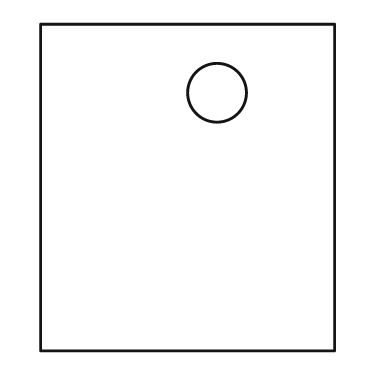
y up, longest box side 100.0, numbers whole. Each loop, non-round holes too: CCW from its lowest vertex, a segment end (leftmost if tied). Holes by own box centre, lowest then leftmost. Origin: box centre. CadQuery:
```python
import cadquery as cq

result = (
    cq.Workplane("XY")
    .moveTo(-45.0, -50.0)
    .lineTo(45.0, -50.0)
    .lineTo(45.0, 50.0)
    .lineTo(-45.0, 50.0)
    .close()
    .moveTo(9.0, 29.0)
    .circle(9.0)
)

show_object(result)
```